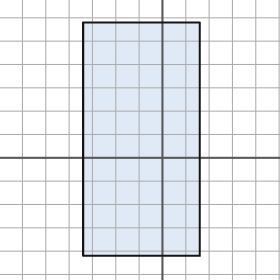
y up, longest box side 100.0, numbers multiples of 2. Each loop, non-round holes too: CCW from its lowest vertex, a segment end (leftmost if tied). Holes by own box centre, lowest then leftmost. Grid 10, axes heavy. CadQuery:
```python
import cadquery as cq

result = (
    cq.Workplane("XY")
    .moveTo(-34.0, -42.0)
    .lineTo(16.0, -42.0)
    .lineTo(16.0, 58.0)
    .lineTo(-34.0, 58.0)
    .close()
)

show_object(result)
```